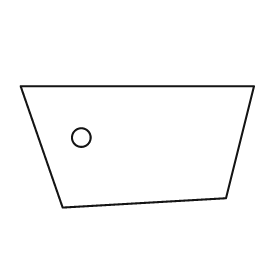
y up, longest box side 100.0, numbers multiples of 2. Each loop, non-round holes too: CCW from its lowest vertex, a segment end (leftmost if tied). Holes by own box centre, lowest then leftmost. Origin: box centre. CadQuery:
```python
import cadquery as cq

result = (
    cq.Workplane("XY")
    .moveTo(-32.0, -26.0)
    .lineTo(38.0, -22.0)
    .lineTo(50.0, 26.0)
    .lineTo(-50.0, 26.0)
    .close()
    .moveTo(-24.0, 4.0)
    .circle(4.0)
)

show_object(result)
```